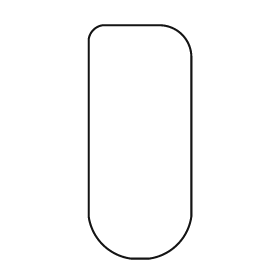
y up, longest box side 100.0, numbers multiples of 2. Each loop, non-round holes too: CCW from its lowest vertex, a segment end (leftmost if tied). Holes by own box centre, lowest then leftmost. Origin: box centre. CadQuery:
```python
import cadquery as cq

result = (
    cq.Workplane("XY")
    .moveTo(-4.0, -50.0)
    .lineTo(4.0, -50.0)
    .threePointArc((16.0, -44.0), (22.0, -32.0))
    .lineTo(22.0, 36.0)
    .threePointArc((18.0, 46.0), (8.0, 50.0))
    .lineTo(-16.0, 50.0)
    .threePointArc((-20.0, 48.0), (-22.0, 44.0))
    .lineTo(-22.0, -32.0)
    .threePointArc((-16.0, -44.0), (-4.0, -50.0))
    .close()
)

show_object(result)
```